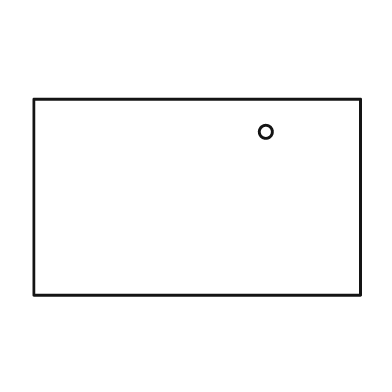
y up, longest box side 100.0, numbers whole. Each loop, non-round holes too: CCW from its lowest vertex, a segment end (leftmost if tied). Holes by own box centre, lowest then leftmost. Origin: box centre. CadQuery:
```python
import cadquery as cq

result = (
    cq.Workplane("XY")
    .moveTo(-50.0, -30.0)
    .lineTo(50.0, -30.0)
    .lineTo(50.0, 30.0)
    .lineTo(-50.0, 30.0)
    .close()
    .moveTo(21.0, 20.0)
    .circle(2.0)
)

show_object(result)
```